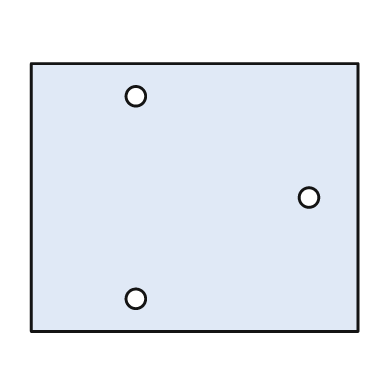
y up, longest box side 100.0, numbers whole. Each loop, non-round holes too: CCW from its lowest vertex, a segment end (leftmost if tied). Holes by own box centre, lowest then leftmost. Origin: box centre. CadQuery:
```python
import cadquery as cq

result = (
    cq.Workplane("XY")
    .moveTo(-50.0, -41.0)
    .lineTo(50.0, -41.0)
    .lineTo(50.0, 41.0)
    .lineTo(-50.0, 41.0)
    .close()
    .moveTo(-18.0, -31.0)
    .circle(3.0)
    .moveTo(35.0, 0.0)
    .circle(3.0)
    .moveTo(-18.0, 31.0)
    .circle(3.0)
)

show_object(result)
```